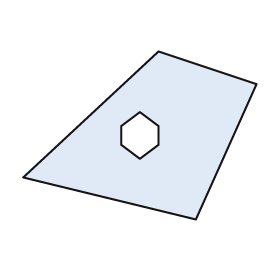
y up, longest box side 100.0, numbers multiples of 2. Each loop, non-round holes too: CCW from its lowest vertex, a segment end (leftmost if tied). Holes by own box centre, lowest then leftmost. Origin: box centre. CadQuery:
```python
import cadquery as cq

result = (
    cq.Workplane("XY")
    .moveTo(24.0, -36.0)
    .lineTo(50.0, 22.0)
    .lineTo(8.0, 36.0)
    .lineTo(-50.0, -18.0)
    .close()
    .moveTo(0.0, -10.0)
    .lineTo(8.0, -4.0)
    .lineTo(8.0, 4.0)
    .lineTo(0.0, 10.0)
    .lineTo(-8.0, 4.0)
    .lineTo(-8.0, -4.0)
    .close()
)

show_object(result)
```